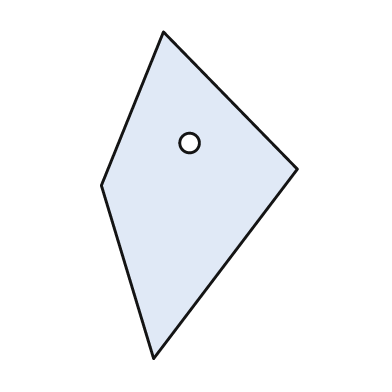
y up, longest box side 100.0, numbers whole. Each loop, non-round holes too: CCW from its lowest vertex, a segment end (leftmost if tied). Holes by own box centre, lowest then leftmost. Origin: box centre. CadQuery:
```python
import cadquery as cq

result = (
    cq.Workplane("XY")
    .moveTo(-14.0, -50.0)
    .lineTo(30.0, 8.0)
    .lineTo(-11.0, 50.0)
    .lineTo(-30.0, 3.0)
    .close()
    .moveTo(-3.0, 16.0)
    .circle(3.0)
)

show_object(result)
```